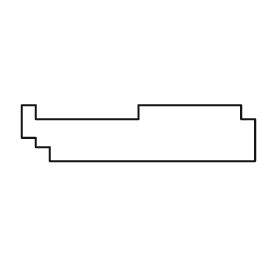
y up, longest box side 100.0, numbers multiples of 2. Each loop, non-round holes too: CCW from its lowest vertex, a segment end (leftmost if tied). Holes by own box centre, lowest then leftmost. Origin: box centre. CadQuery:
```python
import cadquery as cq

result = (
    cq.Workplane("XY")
    .moveTo(-38.0, -12.0)
    .lineTo(50.0, -12.0)
    .lineTo(50.0, 6.0)
    .lineTo(44.0, 6.0)
    .lineTo(44.0, 12.0)
    .lineTo(0.0, 12.0)
    .lineTo(0.0, 6.0)
    .lineTo(-44.0, 6.0)
    .lineTo(-44.0, 12.0)
    .lineTo(-50.0, 12.0)
    .lineTo(-50.0, -2.0)
    .lineTo(-44.0, -2.0)
    .lineTo(-44.0, -6.0)
    .lineTo(-38.0, -6.0)
    .close()
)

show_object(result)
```